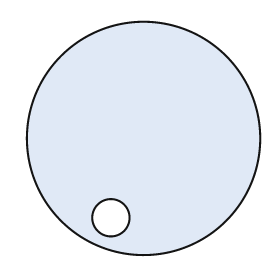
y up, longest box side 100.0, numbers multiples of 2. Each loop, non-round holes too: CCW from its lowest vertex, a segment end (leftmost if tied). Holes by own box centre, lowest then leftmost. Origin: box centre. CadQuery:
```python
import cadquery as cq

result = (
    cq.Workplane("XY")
    .moveTo(0.0, 0.0)
    .circle(50.0)
    .moveTo(-14.0, -34.0)
    .circle(8.0)
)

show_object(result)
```